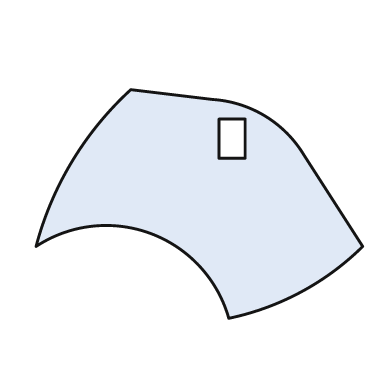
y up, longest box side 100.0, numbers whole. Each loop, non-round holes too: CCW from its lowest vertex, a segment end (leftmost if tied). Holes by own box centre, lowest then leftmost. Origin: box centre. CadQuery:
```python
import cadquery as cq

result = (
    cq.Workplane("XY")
    .moveTo(9.0, -35.0)
    .threePointArc((31.0, -27.0), (50.0, -13.0))
    .lineTo(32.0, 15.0)
    .threePointArc((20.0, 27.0), (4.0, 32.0))
    .lineTo(-21.0, 35.0)
    .threePointArc((-39.0, 13.0), (-50.0, -13.0))
    .threePointArc((-15.0, -9.0), (9.0, -35.0))
    .close()
    .moveTo(6.0, 14.0)
    .lineTo(14.0, 14.0)
    .lineTo(14.0, 26.0)
    .lineTo(6.0, 26.0)
    .close()
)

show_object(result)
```